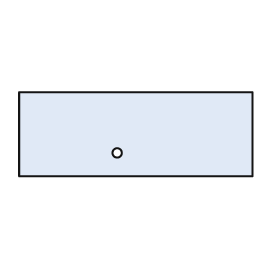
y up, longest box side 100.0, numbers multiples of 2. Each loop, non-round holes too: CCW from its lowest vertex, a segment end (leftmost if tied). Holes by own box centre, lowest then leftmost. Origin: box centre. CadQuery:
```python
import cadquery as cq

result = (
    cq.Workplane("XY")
    .moveTo(-50.0, -18.0)
    .lineTo(50.0, -18.0)
    .lineTo(50.0, 18.0)
    .lineTo(-50.0, 18.0)
    .close()
    .moveTo(-8.0, -8.0)
    .circle(2.0)
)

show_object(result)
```